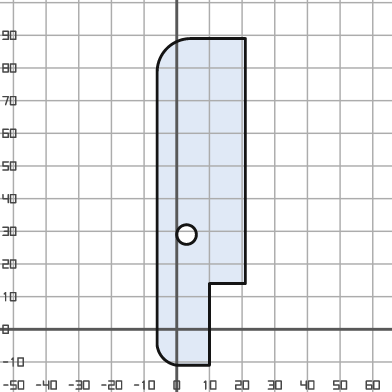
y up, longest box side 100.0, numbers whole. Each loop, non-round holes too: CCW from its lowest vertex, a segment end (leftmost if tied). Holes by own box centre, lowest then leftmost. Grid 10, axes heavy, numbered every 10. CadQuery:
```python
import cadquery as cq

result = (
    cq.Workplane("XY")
    .moveTo(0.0, -11.0)
    .lineTo(10.0, -11.0)
    .lineTo(10.0, 14.0)
    .lineTo(21.0, 14.0)
    .lineTo(21.0, 89.0)
    .lineTo(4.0, 89.0)
    .threePointArc((-3.0, 86.0), (-6.0, 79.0))
    .lineTo(-6.0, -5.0)
    .threePointArc((-4.0, -9.0), (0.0, -11.0))
    .close()
    .moveTo(3.0, 29.0)
    .circle(3.0)
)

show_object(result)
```